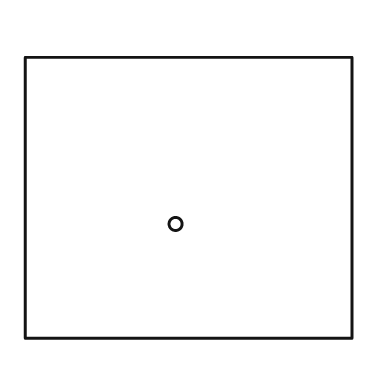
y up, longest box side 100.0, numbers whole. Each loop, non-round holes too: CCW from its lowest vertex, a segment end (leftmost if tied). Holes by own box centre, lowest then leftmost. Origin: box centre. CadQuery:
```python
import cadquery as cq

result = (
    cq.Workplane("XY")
    .moveTo(-50.0, -43.0)
    .lineTo(50.0, -43.0)
    .lineTo(50.0, 43.0)
    .lineTo(-50.0, 43.0)
    .close()
    .moveTo(-4.0, -8.0)
    .circle(2.0)
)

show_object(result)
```